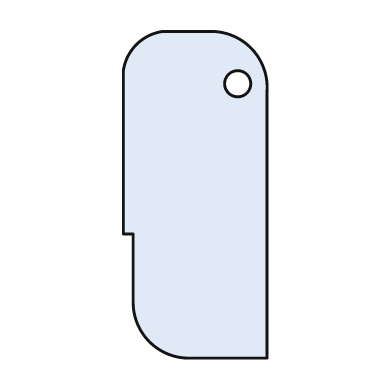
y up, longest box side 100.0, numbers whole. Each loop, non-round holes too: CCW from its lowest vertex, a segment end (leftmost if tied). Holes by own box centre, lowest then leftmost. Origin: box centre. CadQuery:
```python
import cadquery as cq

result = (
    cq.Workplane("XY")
    .moveTo(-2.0, -50.0)
    .lineTo(22.0, -50.0)
    .lineTo(22.0, 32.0)
    .threePointArc((17.0, 45.0), (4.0, 50.0))
    .lineTo(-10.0, 50.0)
    .threePointArc((-18.0, 46.0), (-22.0, 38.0))
    .lineTo(-22.0, -12.0)
    .lineTo(-19.0, -12.0)
    .lineTo(-19.0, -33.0)
    .threePointArc((-14.0, -45.0), (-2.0, -50.0))
    .close()
    .moveTo(13.0, 34.0)
    .circle(4.0)
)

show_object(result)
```